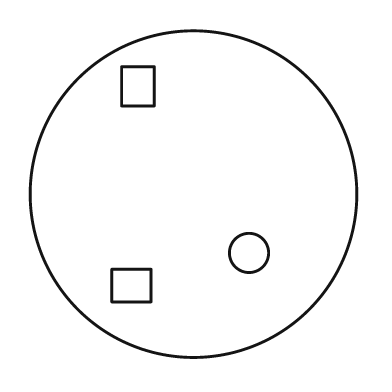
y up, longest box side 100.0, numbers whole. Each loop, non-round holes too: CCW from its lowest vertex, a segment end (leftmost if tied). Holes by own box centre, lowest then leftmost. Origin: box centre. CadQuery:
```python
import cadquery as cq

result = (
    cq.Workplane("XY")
    .moveTo(0.0, 0.0)
    .circle(50.0)
    .moveTo(-25.0, -33.0)
    .lineTo(-13.0, -33.0)
    .lineTo(-13.0, -23.0)
    .lineTo(-25.0, -23.0)
    .close()
    .moveTo(17.0, -18.0)
    .circle(6.0)
    .moveTo(-22.0, 27.0)
    .lineTo(-12.0, 27.0)
    .lineTo(-12.0, 39.0)
    .lineTo(-22.0, 39.0)
    .close()
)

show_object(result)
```